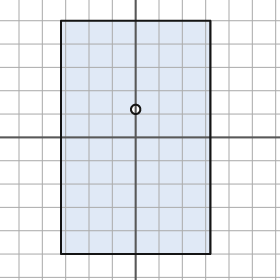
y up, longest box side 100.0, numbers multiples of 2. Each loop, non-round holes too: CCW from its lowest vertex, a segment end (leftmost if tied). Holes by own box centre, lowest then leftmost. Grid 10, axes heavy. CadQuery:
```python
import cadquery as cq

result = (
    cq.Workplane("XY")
    .moveTo(-32.0, -50.0)
    .lineTo(32.0, -50.0)
    .lineTo(32.0, 50.0)
    .lineTo(-32.0, 50.0)
    .close()
    .moveTo(0.0, 12.0)
    .circle(2.0)
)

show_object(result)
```